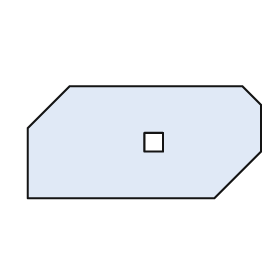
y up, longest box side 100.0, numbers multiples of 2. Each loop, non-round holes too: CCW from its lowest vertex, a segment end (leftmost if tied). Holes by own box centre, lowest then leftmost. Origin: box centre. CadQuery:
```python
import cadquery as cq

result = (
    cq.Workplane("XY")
    .moveTo(-50.0, -24.0)
    .lineTo(30.0, -24.0)
    .lineTo(50.0, -4.0)
    .lineTo(50.0, 16.0)
    .lineTo(42.0, 24.0)
    .lineTo(-32.0, 24.0)
    .lineTo(-50.0, 6.0)
    .close()
    .moveTo(0.0, -4.0)
    .lineTo(8.0, -4.0)
    .lineTo(8.0, 4.0)
    .lineTo(0.0, 4.0)
    .close()
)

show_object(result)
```